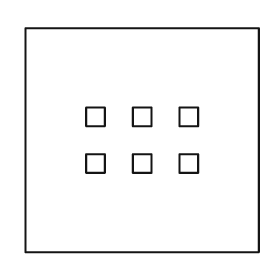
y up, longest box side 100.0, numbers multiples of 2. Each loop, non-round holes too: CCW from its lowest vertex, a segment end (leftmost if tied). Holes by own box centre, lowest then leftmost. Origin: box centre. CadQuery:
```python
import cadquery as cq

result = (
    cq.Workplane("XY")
    .moveTo(-50.0, -48.0)
    .lineTo(50.0, -48.0)
    .lineTo(50.0, 48.0)
    .lineTo(-50.0, 48.0)
    .close()
    .moveTo(-24.0, -14.0)
    .lineTo(-16.0, -14.0)
    .lineTo(-16.0, -6.0)
    .lineTo(-24.0, -6.0)
    .close()
    .moveTo(-4.0, -14.0)
    .lineTo(4.0, -14.0)
    .lineTo(4.0, -6.0)
    .lineTo(-4.0, -6.0)
    .close()
    .moveTo(16.0, -14.0)
    .lineTo(24.0, -14.0)
    .lineTo(24.0, -6.0)
    .lineTo(16.0, -6.0)
    .close()
    .moveTo(-24.0, 6.0)
    .lineTo(-16.0, 6.0)
    .lineTo(-16.0, 14.0)
    .lineTo(-24.0, 14.0)
    .close()
    .moveTo(-4.0, 6.0)
    .lineTo(4.0, 6.0)
    .lineTo(4.0, 14.0)
    .lineTo(-4.0, 14.0)
    .close()
    .moveTo(16.0, 6.0)
    .lineTo(24.0, 6.0)
    .lineTo(24.0, 14.0)
    .lineTo(16.0, 14.0)
    .close()
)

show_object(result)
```